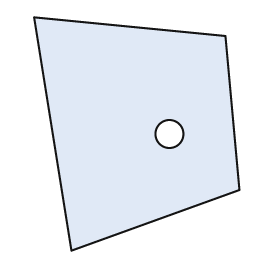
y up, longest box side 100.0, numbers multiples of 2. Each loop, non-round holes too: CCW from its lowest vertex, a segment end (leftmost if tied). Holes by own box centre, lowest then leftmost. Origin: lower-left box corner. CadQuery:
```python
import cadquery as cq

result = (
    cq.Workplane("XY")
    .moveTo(16.0, 0.0)
    .lineTo(88.0, 26.0)
    .lineTo(82.0, 92.0)
    .lineTo(0.0, 100.0)
    .close()
    .moveTo(58.0, 50.0)
    .circle(6.0)
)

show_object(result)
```